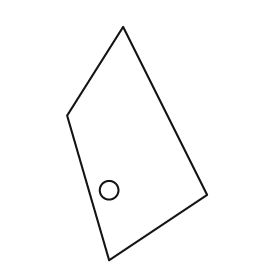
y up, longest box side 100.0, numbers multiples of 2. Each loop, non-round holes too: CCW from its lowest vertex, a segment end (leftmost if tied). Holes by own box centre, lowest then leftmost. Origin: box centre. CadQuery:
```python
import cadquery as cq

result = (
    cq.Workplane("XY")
    .moveTo(-12.0, -50.0)
    .lineTo(30.0, -22.0)
    .lineTo(-6.0, 50.0)
    .lineTo(-30.0, 12.0)
    .close()
    .moveTo(-12.0, -20.0)
    .circle(4.0)
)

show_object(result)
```